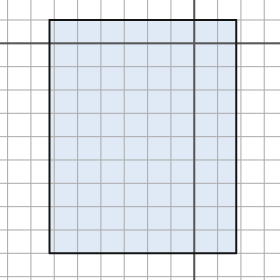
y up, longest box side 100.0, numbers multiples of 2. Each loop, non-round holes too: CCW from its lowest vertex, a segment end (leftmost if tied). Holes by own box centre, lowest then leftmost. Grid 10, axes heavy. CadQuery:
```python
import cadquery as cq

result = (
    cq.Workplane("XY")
    .moveTo(-62.0, -90.0)
    .lineTo(18.0, -90.0)
    .lineTo(18.0, 10.0)
    .lineTo(-62.0, 10.0)
    .close()
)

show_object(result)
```